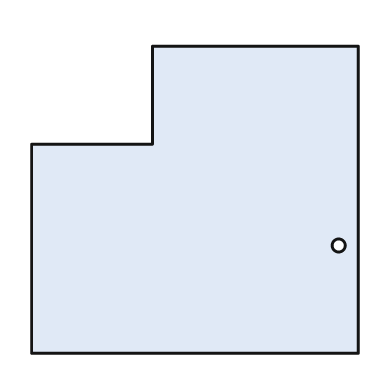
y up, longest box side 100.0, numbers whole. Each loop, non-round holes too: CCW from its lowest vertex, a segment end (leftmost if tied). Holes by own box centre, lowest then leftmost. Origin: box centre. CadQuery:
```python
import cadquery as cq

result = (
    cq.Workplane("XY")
    .moveTo(-50.0, -47.0)
    .lineTo(50.0, -47.0)
    .lineTo(50.0, 47.0)
    .lineTo(-13.0, 47.0)
    .lineTo(-13.0, 17.0)
    .lineTo(-50.0, 17.0)
    .close()
    .moveTo(44.0, -14.0)
    .circle(2.0)
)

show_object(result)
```